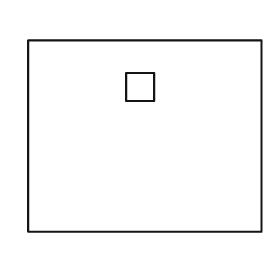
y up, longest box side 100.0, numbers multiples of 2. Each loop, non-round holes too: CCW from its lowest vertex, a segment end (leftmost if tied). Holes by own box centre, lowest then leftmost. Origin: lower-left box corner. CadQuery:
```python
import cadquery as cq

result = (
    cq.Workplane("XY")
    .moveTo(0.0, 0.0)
    .lineTo(100.0, 0.0)
    .lineTo(100.0, 82.0)
    .lineTo(0.0, 82.0)
    .close()
    .moveTo(42.0, 56.0)
    .lineTo(54.0, 56.0)
    .lineTo(54.0, 68.0)
    .lineTo(42.0, 68.0)
    .close()
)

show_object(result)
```